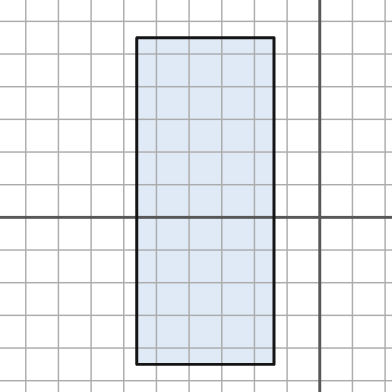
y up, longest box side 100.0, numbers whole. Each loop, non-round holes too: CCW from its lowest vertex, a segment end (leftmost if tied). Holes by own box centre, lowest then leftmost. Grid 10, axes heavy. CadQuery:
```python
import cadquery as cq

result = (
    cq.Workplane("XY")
    .moveTo(-56.0, -45.0)
    .lineTo(-14.0, -45.0)
    .lineTo(-14.0, 55.0)
    .lineTo(-56.0, 55.0)
    .close()
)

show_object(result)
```